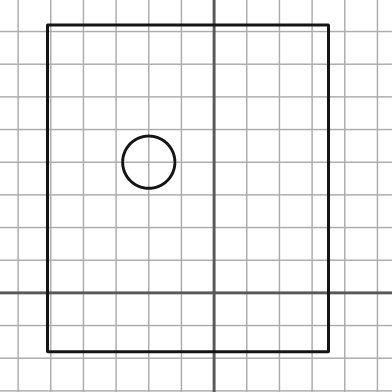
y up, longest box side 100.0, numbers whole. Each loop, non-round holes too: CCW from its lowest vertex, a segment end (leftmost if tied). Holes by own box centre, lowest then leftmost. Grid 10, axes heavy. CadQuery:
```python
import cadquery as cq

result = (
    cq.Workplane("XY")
    .moveTo(-51.0, -18.0)
    .lineTo(35.0, -18.0)
    .lineTo(35.0, 82.0)
    .lineTo(-51.0, 82.0)
    .close()
    .moveTo(-20.0, 40.0)
    .circle(8.0)
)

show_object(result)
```